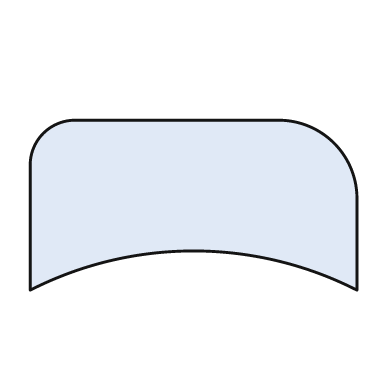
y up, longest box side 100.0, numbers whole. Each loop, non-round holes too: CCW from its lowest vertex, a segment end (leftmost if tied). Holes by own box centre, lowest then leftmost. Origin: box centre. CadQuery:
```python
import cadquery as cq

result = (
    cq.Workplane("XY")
    .moveTo(-50.0, -26.0)
    .threePointArc((0.0, -14.0), (50.0, -26.0))
    .lineTo(50.0, 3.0)
    .threePointArc((43.0, 19.0), (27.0, 26.0))
    .lineTo(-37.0, 26.0)
    .threePointArc((-46.0, 22.0), (-50.0, 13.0))
    .close()
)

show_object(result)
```